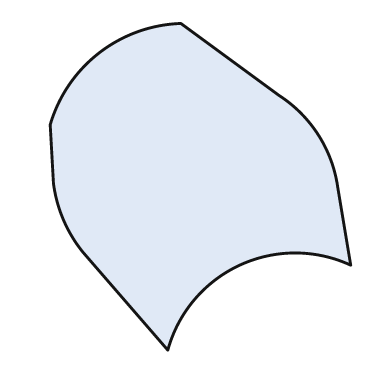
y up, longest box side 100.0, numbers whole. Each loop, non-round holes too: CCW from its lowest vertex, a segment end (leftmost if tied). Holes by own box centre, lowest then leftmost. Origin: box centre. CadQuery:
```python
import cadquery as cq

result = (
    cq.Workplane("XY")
    .moveTo(-10.0, -50.0)
    .threePointArc((12.0, -24.0), (46.0, -24.0))
    .lineTo(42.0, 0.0)
    .threePointArc((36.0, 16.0), (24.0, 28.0))
    .lineTo(-6.0, 50.0)
    .threePointArc((-31.0, 41.0), (-46.0, 19.0))
    .lineTo(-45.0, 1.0)
    .threePointArc((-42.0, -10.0), (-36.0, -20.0))
    .close()
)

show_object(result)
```